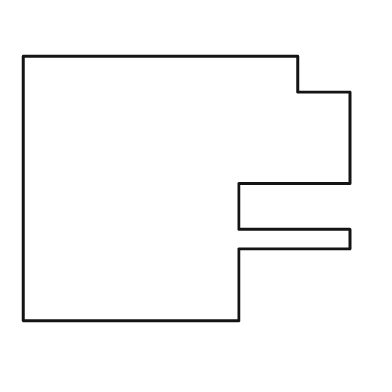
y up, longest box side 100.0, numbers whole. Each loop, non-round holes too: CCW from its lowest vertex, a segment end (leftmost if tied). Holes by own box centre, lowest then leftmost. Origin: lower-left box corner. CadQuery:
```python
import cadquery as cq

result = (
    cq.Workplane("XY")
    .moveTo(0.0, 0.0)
    .lineTo(66.0, 0.0)
    .lineTo(66.0, 22.0)
    .lineTo(100.0, 22.0)
    .lineTo(100.0, 28.0)
    .lineTo(66.0, 28.0)
    .lineTo(66.0, 42.0)
    .lineTo(100.0, 42.0)
    .lineTo(100.0, 70.0)
    .lineTo(84.0, 70.0)
    .lineTo(84.0, 81.0)
    .lineTo(0.0, 81.0)
    .close()
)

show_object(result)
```